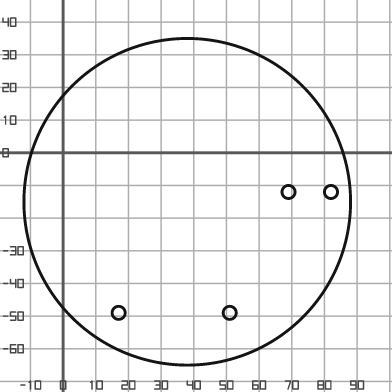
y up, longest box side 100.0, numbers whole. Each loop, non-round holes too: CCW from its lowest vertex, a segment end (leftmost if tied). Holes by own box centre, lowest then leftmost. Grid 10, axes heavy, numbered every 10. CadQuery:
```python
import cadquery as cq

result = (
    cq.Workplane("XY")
    .moveTo(38.0, -15.0)
    .circle(50.0)
    .moveTo(17.0, -49.0)
    .circle(2.0)
    .moveTo(51.0, -49.0)
    .circle(2.0)
    .moveTo(69.0, -12.0)
    .circle(2.0)
    .moveTo(82.0, -12.0)
    .circle(2.0)
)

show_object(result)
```